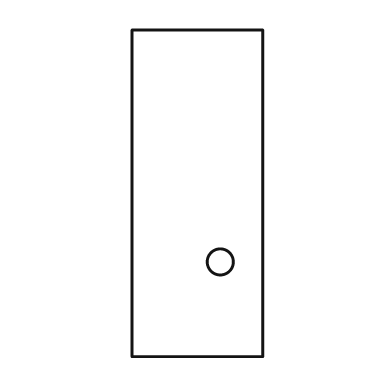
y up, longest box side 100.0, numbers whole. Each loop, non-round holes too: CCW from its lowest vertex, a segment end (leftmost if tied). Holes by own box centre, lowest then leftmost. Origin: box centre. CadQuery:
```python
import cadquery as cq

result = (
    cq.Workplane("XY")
    .moveTo(-20.0, -50.0)
    .lineTo(20.0, -50.0)
    .lineTo(20.0, 50.0)
    .lineTo(-20.0, 50.0)
    .close()
    .moveTo(7.0, -21.0)
    .circle(4.0)
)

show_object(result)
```